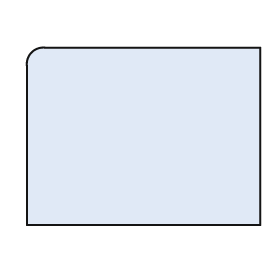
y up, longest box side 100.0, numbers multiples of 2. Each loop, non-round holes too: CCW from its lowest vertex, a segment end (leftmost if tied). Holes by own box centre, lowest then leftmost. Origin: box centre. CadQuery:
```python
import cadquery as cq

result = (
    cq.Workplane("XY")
    .moveTo(-50.0, -38.0)
    .lineTo(50.0, -38.0)
    .lineTo(50.0, 38.0)
    .lineTo(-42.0, 38.0)
    .threePointArc((-48.0, 36.0), (-50.0, 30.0))
    .close()
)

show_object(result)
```